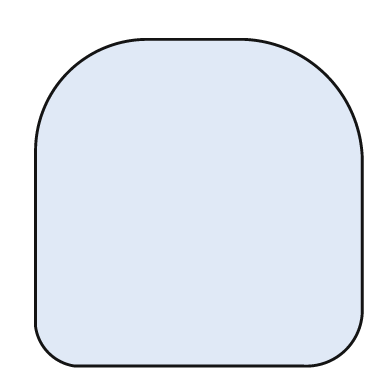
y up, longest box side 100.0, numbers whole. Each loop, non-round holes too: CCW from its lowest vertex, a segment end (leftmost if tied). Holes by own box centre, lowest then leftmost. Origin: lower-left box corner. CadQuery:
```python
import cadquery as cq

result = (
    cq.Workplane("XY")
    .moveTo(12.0, 0.0)
    .lineTo(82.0, 0.0)
    .threePointArc((95.0, 5.0), (100.0, 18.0))
    .lineTo(100.0, 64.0)
    .threePointArc((89.0, 89.0), (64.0, 100.0))
    .lineTo(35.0, 100.0)
    .threePointArc((10.0, 90.0), (0.0, 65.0))
    .lineTo(0.0, 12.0)
    .threePointArc((4.0, 4.0), (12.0, 0.0))
    .close()
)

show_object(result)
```